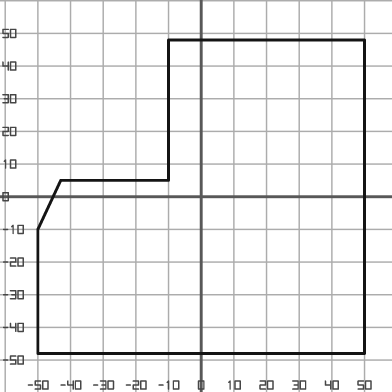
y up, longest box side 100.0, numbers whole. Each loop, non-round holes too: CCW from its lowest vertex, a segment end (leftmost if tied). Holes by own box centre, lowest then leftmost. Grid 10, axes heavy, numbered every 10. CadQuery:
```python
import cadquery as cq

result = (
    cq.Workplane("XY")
    .moveTo(-50.0, -48.0)
    .lineTo(50.0, -48.0)
    .lineTo(50.0, 48.0)
    .lineTo(-10.0, 48.0)
    .lineTo(-10.0, 5.0)
    .lineTo(-43.0, 5.0)
    .lineTo(-50.0, -10.0)
    .close()
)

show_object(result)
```